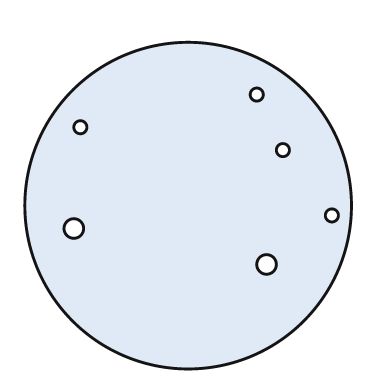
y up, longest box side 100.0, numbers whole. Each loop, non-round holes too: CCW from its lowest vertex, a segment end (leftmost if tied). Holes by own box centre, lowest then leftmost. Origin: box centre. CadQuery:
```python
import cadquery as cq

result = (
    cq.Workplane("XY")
    .moveTo(0.0, 0.0)
    .circle(50.0)
    .moveTo(24.0, -18.0)
    .circle(3.0)
    .moveTo(-35.0, -7.0)
    .circle(3.0)
    .moveTo(44.0, -3.0)
    .circle(2.0)
    .moveTo(29.0, 17.0)
    .circle(2.0)
    .moveTo(-33.0, 24.0)
    .circle(2.0)
    .moveTo(21.0, 34.0)
    .circle(2.0)
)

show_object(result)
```